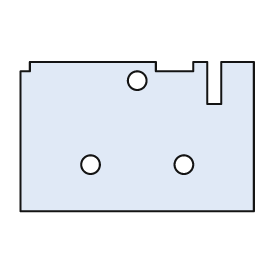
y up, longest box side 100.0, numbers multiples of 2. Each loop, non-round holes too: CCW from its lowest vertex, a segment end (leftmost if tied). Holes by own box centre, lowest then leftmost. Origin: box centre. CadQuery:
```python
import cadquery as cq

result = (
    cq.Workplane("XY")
    .moveTo(-50.0, -32.0)
    .lineTo(50.0, -32.0)
    .lineTo(50.0, 32.0)
    .lineTo(36.0, 32.0)
    .lineTo(36.0, 14.0)
    .lineTo(30.0, 14.0)
    .lineTo(30.0, 32.0)
    .lineTo(24.0, 32.0)
    .lineTo(24.0, 28.0)
    .lineTo(8.0, 28.0)
    .lineTo(8.0, 32.0)
    .lineTo(-46.0, 32.0)
    .lineTo(-46.0, 28.0)
    .lineTo(-50.0, 28.0)
    .close()
    .moveTo(-20.0, -12.0)
    .circle(4.0)
    .moveTo(20.0, -12.0)
    .circle(4.0)
    .moveTo(0.0, 24.0)
    .circle(4.0)
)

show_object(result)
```